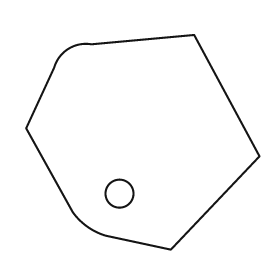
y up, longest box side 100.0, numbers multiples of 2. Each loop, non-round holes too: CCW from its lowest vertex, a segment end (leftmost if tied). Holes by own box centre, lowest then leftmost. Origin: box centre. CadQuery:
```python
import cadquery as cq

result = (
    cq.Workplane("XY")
    .moveTo(12.0, -46.0)
    .lineTo(50.0, -6.0)
    .lineTo(22.0, 46.0)
    .lineTo(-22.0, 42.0)
    .threePointArc((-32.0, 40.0), (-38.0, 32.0))
    .lineTo(-50.0, 6.0)
    .lineTo(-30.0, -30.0)
    .threePointArc((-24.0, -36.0), (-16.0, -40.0))
    .close()
    .moveTo(-10.0, -22.0)
    .circle(6.0)
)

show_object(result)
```